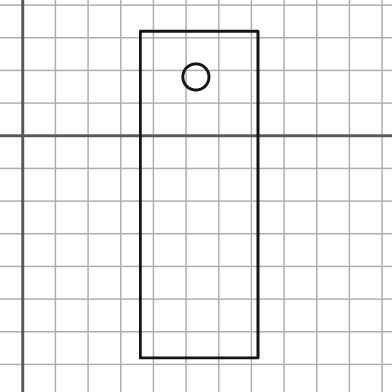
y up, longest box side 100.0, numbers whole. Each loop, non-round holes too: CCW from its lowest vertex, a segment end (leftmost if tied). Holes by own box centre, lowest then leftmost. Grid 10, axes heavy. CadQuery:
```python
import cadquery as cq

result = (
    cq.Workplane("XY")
    .moveTo(36.0, -68.0)
    .lineTo(72.0, -68.0)
    .lineTo(72.0, 32.0)
    .lineTo(36.0, 32.0)
    .close()
    .moveTo(53.0, 18.0)
    .circle(4.0)
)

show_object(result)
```